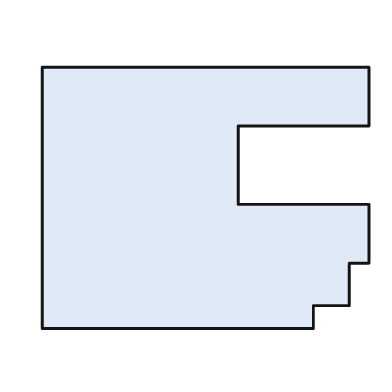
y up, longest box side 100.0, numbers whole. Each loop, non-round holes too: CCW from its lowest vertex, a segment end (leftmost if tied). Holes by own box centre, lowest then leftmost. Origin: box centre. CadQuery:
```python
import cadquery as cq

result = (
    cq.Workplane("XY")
    .moveTo(-50.0, -40.0)
    .lineTo(33.0, -40.0)
    .lineTo(33.0, -33.0)
    .lineTo(44.0, -33.0)
    .lineTo(44.0, -20.0)
    .lineTo(50.0, -20.0)
    .lineTo(50.0, -2.0)
    .lineTo(10.0, -2.0)
    .lineTo(10.0, 22.0)
    .lineTo(50.0, 22.0)
    .lineTo(50.0, 40.0)
    .lineTo(-50.0, 40.0)
    .close()
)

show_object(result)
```